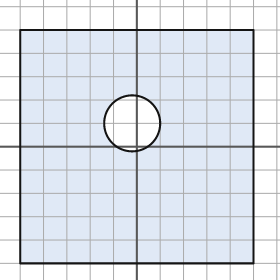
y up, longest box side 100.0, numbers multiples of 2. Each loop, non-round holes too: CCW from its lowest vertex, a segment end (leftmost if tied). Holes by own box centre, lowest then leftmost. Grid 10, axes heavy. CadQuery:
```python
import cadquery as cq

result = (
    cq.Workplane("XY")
    .moveTo(-50.0, -50.0)
    .lineTo(50.0, -50.0)
    .lineTo(50.0, 50.0)
    .lineTo(-50.0, 50.0)
    .close()
    .moveTo(-2.0, 10.0)
    .circle(12.0)
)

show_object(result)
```